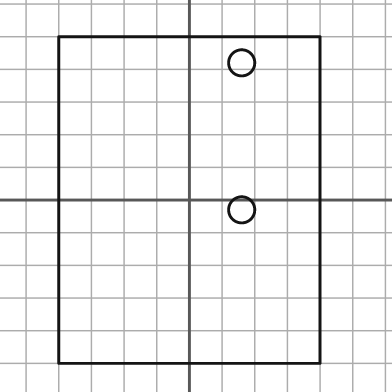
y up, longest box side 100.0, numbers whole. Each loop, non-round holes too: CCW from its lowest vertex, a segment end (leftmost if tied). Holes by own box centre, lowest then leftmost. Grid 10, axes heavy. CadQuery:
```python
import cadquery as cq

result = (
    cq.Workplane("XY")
    .moveTo(-40.0, -50.0)
    .lineTo(40.0, -50.0)
    .lineTo(40.0, 50.0)
    .lineTo(-40.0, 50.0)
    .close()
    .moveTo(16.0, -3.0)
    .circle(4.0)
    .moveTo(16.0, 42.0)
    .circle(4.0)
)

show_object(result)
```